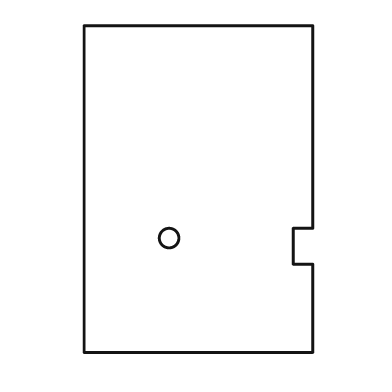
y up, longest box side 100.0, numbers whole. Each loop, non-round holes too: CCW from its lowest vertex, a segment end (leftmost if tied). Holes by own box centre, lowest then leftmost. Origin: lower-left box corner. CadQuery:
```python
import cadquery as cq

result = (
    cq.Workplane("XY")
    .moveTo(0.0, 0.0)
    .lineTo(70.0, 0.0)
    .lineTo(70.0, 27.0)
    .lineTo(64.0, 27.0)
    .lineTo(64.0, 38.0)
    .lineTo(70.0, 38.0)
    .lineTo(70.0, 100.0)
    .lineTo(0.0, 100.0)
    .close()
    .moveTo(26.0, 35.0)
    .circle(3.0)
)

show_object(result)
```